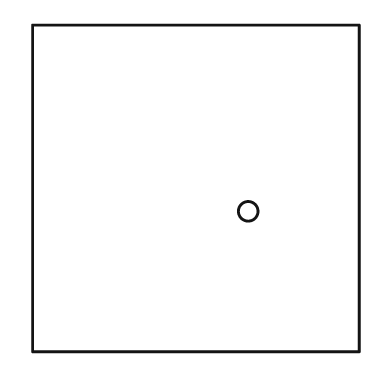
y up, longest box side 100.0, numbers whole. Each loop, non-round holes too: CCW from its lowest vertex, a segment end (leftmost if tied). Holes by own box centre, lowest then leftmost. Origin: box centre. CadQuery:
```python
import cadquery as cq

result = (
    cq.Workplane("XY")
    .moveTo(-50.0, -50.0)
    .lineTo(50.0, -50.0)
    .lineTo(50.0, 50.0)
    .lineTo(-50.0, 50.0)
    .close()
    .moveTo(16.0, -7.0)
    .circle(3.0)
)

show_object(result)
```